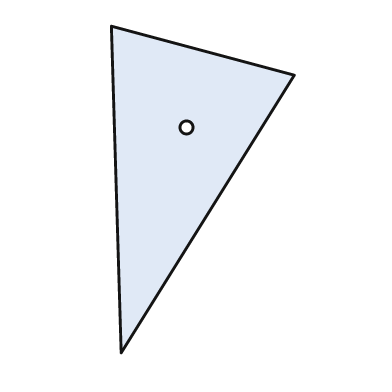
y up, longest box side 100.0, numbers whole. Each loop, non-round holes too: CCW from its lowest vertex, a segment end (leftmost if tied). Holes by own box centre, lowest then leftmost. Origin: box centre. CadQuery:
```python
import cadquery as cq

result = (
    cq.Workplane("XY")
    .moveTo(-25.0, -50.0)
    .lineTo(28.0, 35.0)
    .lineTo(-28.0, 50.0)
    .close()
    .moveTo(-5.0, 19.0)
    .circle(2.0)
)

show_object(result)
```